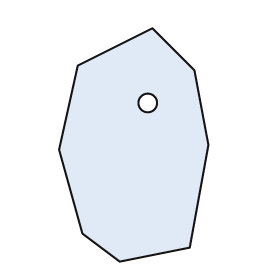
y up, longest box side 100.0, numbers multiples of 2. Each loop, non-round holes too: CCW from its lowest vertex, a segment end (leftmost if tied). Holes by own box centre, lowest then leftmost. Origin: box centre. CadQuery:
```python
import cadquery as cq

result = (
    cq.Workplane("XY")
    .moveTo(-6.0, -50.0)
    .lineTo(24.0, -44.0)
    .lineTo(32.0, 0.0)
    .lineTo(26.0, 32.0)
    .lineTo(8.0, 50.0)
    .lineTo(-24.0, 34.0)
    .lineTo(-32.0, -2.0)
    .lineTo(-22.0, -38.0)
    .close()
    .moveTo(6.0, 18.0)
    .circle(4.0)
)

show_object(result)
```